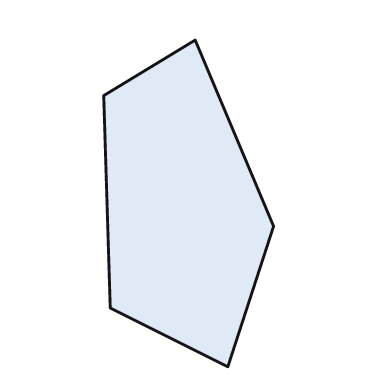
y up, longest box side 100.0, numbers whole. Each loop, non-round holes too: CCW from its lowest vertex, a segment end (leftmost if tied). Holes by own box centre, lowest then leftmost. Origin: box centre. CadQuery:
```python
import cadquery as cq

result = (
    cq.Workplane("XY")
    .moveTo(12.0, -50.0)
    .lineTo(26.0, -7.0)
    .lineTo(2.0, 50.0)
    .lineTo(-26.0, 33.0)
    .lineTo(-24.0, -32.0)
    .close()
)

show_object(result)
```